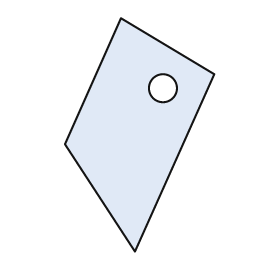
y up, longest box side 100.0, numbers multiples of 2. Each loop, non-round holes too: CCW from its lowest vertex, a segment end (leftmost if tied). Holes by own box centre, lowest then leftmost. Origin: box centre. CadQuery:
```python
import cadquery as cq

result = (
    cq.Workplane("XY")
    .moveTo(-2.0, -50.0)
    .lineTo(32.0, 26.0)
    .lineTo(-8.0, 50.0)
    .lineTo(-32.0, -4.0)
    .close()
    .moveTo(10.0, 20.0)
    .circle(6.0)
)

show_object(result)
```